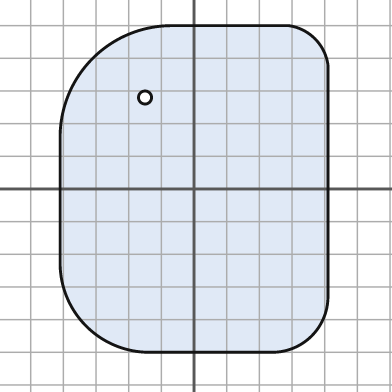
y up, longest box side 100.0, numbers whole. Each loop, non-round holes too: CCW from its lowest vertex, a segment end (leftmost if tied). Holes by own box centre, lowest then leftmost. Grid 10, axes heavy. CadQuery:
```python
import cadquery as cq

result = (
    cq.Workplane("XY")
    .moveTo(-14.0, -50.0)
    .lineTo(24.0, -50.0)
    .threePointArc((36.0, -45.0), (41.0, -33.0))
    .lineTo(41.0, 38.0)
    .threePointArc((37.0, 46.0), (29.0, 50.0))
    .lineTo(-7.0, 50.0)
    .threePointArc((-31.0, 40.0), (-41.0, 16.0))
    .lineTo(-41.0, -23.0)
    .threePointArc((-33.0, -42.0), (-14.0, -50.0))
    .close()
    .moveTo(-15.0, 28.0)
    .circle(2.0)
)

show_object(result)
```